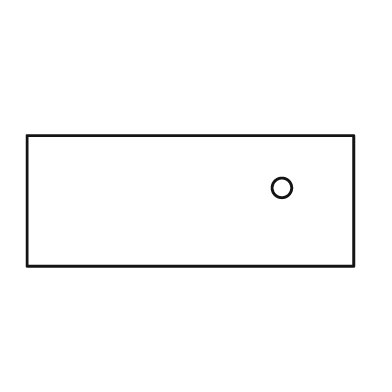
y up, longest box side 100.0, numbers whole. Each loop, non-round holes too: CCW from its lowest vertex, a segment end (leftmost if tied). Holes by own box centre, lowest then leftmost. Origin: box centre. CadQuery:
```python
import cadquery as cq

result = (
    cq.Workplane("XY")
    .moveTo(-50.0, -20.0)
    .lineTo(50.0, -20.0)
    .lineTo(50.0, 20.0)
    .lineTo(-50.0, 20.0)
    .close()
    .moveTo(28.0, 4.0)
    .circle(3.0)
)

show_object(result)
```